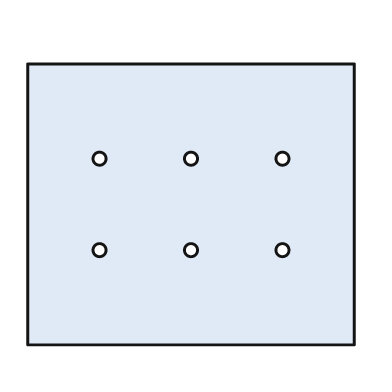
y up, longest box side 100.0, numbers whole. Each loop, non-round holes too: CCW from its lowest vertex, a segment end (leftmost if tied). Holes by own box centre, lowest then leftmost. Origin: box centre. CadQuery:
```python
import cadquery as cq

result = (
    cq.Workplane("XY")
    .moveTo(-50.0, -43.0)
    .lineTo(50.0, -43.0)
    .lineTo(50.0, 43.0)
    .lineTo(-50.0, 43.0)
    .close()
    .moveTo(-28.0, -14.0)
    .circle(2.0)
    .moveTo(0.0, -14.0)
    .circle(2.0)
    .moveTo(28.0, -14.0)
    .circle(2.0)
    .moveTo(-28.0, 14.0)
    .circle(2.0)
    .moveTo(0.0, 14.0)
    .circle(2.0)
    .moveTo(28.0, 14.0)
    .circle(2.0)
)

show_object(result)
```